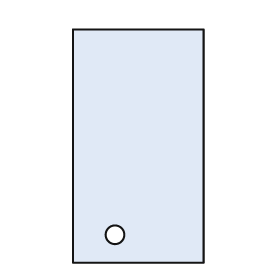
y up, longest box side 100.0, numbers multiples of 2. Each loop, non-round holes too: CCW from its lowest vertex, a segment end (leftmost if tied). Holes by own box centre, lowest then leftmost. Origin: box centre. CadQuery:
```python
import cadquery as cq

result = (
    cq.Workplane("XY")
    .moveTo(-28.0, -50.0)
    .lineTo(28.0, -50.0)
    .lineTo(28.0, 50.0)
    .lineTo(-28.0, 50.0)
    .close()
    .moveTo(-10.0, -38.0)
    .circle(4.0)
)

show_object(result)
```